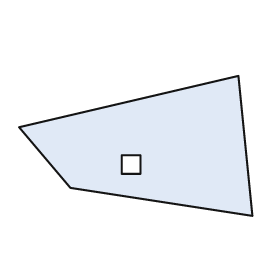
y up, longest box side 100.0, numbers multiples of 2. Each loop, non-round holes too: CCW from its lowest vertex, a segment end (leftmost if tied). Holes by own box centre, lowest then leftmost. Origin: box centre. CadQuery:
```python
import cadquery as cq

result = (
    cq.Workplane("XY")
    .moveTo(50.0, -30.0)
    .lineTo(44.0, 30.0)
    .lineTo(-50.0, 8.0)
    .lineTo(-28.0, -18.0)
    .close()
    .moveTo(-6.0, -12.0)
    .lineTo(2.0, -12.0)
    .lineTo(2.0, -4.0)
    .lineTo(-6.0, -4.0)
    .close()
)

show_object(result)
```